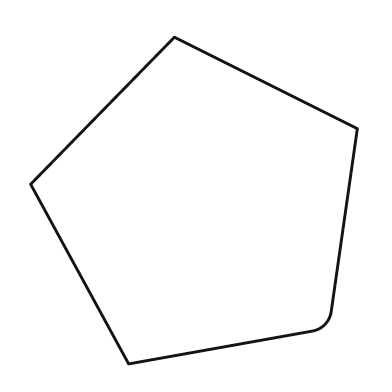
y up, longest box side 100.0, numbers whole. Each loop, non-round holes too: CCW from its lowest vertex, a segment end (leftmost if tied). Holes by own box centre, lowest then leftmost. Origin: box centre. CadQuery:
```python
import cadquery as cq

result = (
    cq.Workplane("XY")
    .moveTo(-20.0, -50.0)
    .lineTo(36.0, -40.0)
    .threePointArc((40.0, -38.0), (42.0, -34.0))
    .lineTo(50.0, 22.0)
    .lineTo(-6.0, 50.0)
    .lineTo(-50.0, 5.0)
    .close()
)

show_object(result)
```